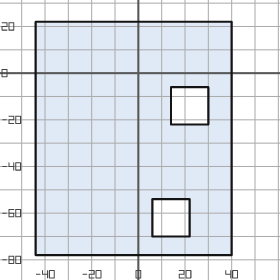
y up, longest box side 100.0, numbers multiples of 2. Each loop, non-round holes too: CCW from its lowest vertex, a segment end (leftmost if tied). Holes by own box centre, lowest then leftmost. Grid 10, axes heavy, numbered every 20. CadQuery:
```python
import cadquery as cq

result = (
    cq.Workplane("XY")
    .moveTo(-44.0, -78.0)
    .lineTo(40.0, -78.0)
    .lineTo(40.0, 22.0)
    .lineTo(-44.0, 22.0)
    .close()
    .moveTo(6.0, -70.0)
    .lineTo(22.0, -70.0)
    .lineTo(22.0, -54.0)
    .lineTo(6.0, -54.0)
    .close()
    .moveTo(14.0, -22.0)
    .lineTo(30.0, -22.0)
    .lineTo(30.0, -6.0)
    .lineTo(14.0, -6.0)
    .close()
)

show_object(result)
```